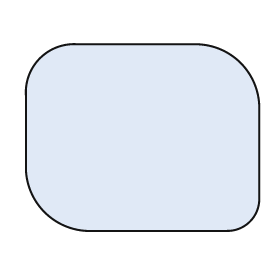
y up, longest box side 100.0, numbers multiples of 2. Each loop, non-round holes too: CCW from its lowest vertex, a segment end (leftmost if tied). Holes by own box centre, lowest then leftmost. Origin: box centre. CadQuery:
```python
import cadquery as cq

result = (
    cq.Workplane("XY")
    .moveTo(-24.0, -40.0)
    .lineTo(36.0, -40.0)
    .threePointArc((46.0, -36.0), (50.0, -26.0))
    .lineTo(50.0, 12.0)
    .threePointArc((42.0, 32.0), (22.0, 40.0))
    .lineTo(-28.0, 40.0)
    .threePointArc((-44.0, 34.0), (-50.0, 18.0))
    .lineTo(-50.0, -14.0)
    .threePointArc((-42.0, -32.0), (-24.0, -40.0))
    .close()
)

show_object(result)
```